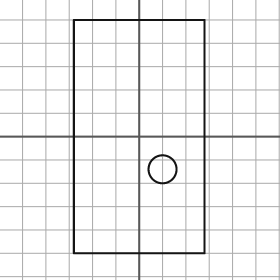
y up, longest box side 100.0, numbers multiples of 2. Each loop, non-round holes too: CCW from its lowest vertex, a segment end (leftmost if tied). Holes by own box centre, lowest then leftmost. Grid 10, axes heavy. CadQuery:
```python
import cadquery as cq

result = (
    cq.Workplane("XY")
    .moveTo(-28.0, -50.0)
    .lineTo(28.0, -50.0)
    .lineTo(28.0, 50.0)
    .lineTo(-28.0, 50.0)
    .close()
    .moveTo(10.0, -14.0)
    .circle(6.0)
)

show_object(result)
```